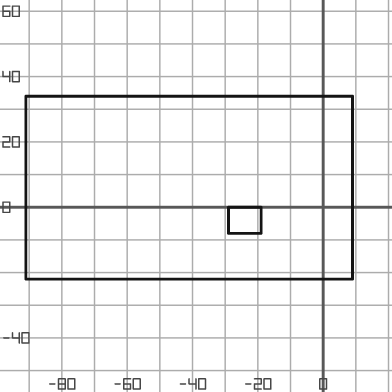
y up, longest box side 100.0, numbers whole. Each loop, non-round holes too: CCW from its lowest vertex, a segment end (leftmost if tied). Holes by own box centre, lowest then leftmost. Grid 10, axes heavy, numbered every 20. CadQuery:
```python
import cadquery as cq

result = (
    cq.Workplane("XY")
    .moveTo(-91.0, -22.0)
    .lineTo(9.0, -22.0)
    .lineTo(9.0, 34.0)
    .lineTo(-91.0, 34.0)
    .close()
    .moveTo(-29.0, -8.0)
    .lineTo(-19.0, -8.0)
    .lineTo(-19.0, 0.0)
    .lineTo(-29.0, 0.0)
    .close()
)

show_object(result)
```